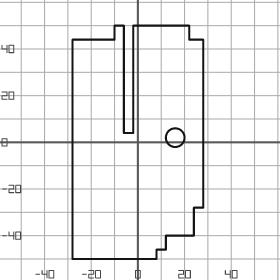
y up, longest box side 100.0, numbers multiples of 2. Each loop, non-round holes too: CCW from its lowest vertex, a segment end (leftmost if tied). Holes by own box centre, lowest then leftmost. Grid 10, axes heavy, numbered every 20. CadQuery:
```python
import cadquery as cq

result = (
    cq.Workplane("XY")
    .moveTo(-28.0, -50.0)
    .lineTo(8.0, -50.0)
    .lineTo(8.0, -46.0)
    .lineTo(12.0, -46.0)
    .lineTo(12.0, -40.0)
    .lineTo(24.0, -40.0)
    .lineTo(24.0, -28.0)
    .lineTo(28.0, -28.0)
    .lineTo(28.0, 44.0)
    .lineTo(22.0, 44.0)
    .lineTo(22.0, 50.0)
    .lineTo(-2.0, 50.0)
    .lineTo(-2.0, 4.0)
    .lineTo(-6.0, 4.0)
    .lineTo(-6.0, 50.0)
    .lineTo(-10.0, 50.0)
    .lineTo(-10.0, 44.0)
    .lineTo(-28.0, 44.0)
    .close()
    .moveTo(16.0, 2.0)
    .circle(4.0)
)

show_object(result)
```